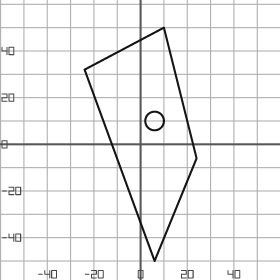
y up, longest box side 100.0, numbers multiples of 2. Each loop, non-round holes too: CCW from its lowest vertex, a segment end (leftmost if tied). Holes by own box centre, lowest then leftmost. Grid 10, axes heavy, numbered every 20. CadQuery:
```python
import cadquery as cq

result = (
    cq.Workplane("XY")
    .moveTo(6.0, -50.0)
    .lineTo(24.0, -6.0)
    .lineTo(10.0, 50.0)
    .lineTo(-24.0, 32.0)
    .close()
    .moveTo(6.0, 10.0)
    .circle(4.0)
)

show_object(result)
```